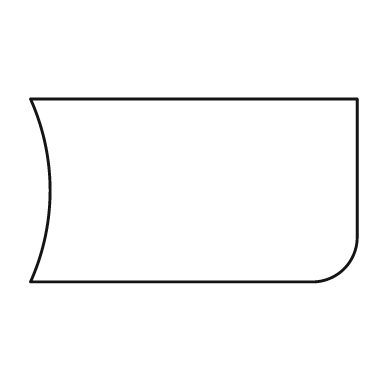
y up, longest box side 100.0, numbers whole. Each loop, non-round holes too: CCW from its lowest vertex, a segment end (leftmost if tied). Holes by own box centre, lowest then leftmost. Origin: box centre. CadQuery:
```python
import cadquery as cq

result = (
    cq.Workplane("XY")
    .moveTo(-50.0, -28.0)
    .lineTo(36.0, -28.0)
    .threePointArc((46.0, -24.0), (50.0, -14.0))
    .lineTo(50.0, 28.0)
    .lineTo(-50.0, 28.0)
    .threePointArc((-44.0, 0.0), (-50.0, -28.0))
    .close()
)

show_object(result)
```